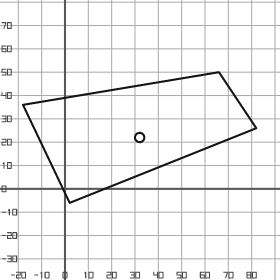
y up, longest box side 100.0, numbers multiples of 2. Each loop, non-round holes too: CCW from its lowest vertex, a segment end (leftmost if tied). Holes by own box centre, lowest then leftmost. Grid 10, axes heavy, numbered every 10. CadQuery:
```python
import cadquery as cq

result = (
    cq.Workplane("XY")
    .moveTo(2.0, -6.0)
    .lineTo(82.0, 26.0)
    .lineTo(66.0, 50.0)
    .lineTo(-18.0, 36.0)
    .close()
    .moveTo(32.0, 22.0)
    .circle(2.0)
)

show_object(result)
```